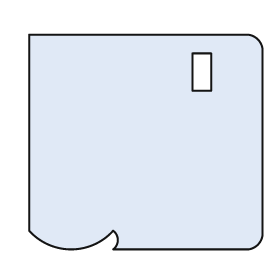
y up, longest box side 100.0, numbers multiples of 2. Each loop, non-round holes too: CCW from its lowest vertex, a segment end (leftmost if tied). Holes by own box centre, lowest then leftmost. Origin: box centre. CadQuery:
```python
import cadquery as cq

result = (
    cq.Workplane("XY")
    .moveTo(-14.0, -46.0)
    .lineTo(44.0, -46.0)
    .threePointArc((48.0, -44.0), (50.0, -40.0))
    .lineTo(50.0, 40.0)
    .threePointArc((48.0, 44.0), (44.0, 46.0))
    .lineTo(-50.0, 46.0)
    .lineTo(-50.0, -38.0)
    .threePointArc((-32.0, -46.0), (-14.0, -38.0))
    .threePointArc((-12.0, -42.0), (-14.0, -46.0))
    .close()
    .moveTo(20.0, 22.0)
    .lineTo(28.0, 22.0)
    .lineTo(28.0, 38.0)
    .lineTo(20.0, 38.0)
    .close()
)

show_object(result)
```